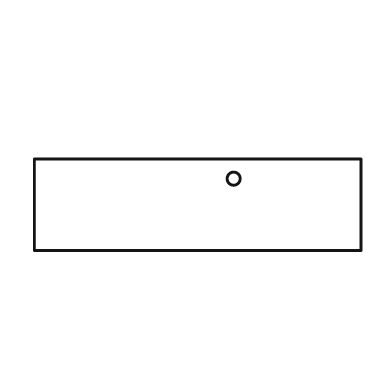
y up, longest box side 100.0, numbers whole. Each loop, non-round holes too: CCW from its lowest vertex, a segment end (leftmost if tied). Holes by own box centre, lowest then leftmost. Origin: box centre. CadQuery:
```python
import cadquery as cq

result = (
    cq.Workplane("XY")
    .moveTo(-50.0, -14.0)
    .lineTo(50.0, -14.0)
    .lineTo(50.0, 14.0)
    .lineTo(-50.0, 14.0)
    .close()
    .moveTo(11.0, 8.0)
    .circle(2.0)
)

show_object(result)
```